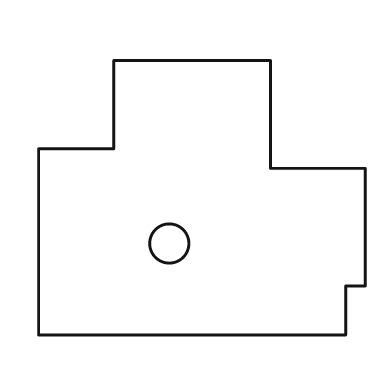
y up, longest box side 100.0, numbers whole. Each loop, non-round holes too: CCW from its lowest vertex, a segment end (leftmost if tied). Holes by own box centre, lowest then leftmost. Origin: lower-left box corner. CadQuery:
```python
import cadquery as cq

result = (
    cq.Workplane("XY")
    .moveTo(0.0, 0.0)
    .lineTo(94.0, 0.0)
    .lineTo(94.0, 15.0)
    .lineTo(100.0, 15.0)
    .lineTo(100.0, 51.0)
    .lineTo(71.0, 51.0)
    .lineTo(71.0, 84.0)
    .lineTo(23.0, 84.0)
    .lineTo(23.0, 57.0)
    .lineTo(0.0, 57.0)
    .close()
    .moveTo(40.0, 28.0)
    .circle(6.0)
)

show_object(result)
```